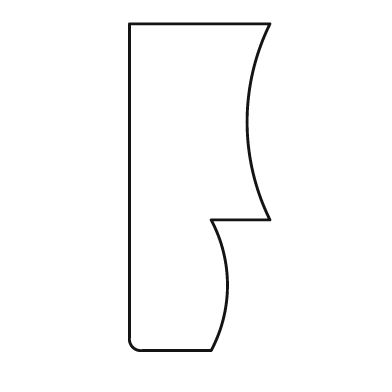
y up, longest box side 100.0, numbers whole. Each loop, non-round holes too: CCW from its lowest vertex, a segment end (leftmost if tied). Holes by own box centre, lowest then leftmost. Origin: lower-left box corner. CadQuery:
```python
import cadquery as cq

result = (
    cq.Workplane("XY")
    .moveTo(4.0, 0.0)
    .lineTo(25.0, 0.0)
    .threePointArc((30.0, 20.0), (25.0, 40.0))
    .lineTo(43.0, 40.0)
    .threePointArc((36.0, 70.0), (43.0, 100.0))
    .lineTo(0.0, 100.0)
    .lineTo(0.0, 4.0)
    .threePointArc((1.0, 1.0), (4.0, 0.0))
    .close()
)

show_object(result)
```